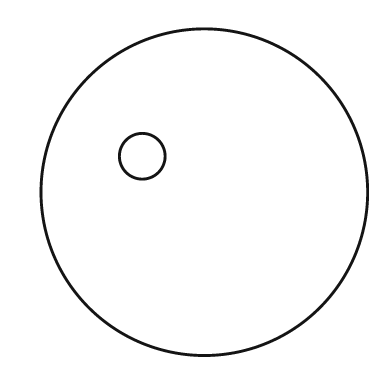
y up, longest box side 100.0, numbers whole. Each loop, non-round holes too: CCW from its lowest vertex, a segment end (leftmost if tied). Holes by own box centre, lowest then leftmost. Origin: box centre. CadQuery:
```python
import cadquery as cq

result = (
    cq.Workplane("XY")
    .moveTo(0.0, 0.0)
    .circle(50.0)
    .moveTo(-19.0, 11.0)
    .circle(7.0)
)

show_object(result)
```